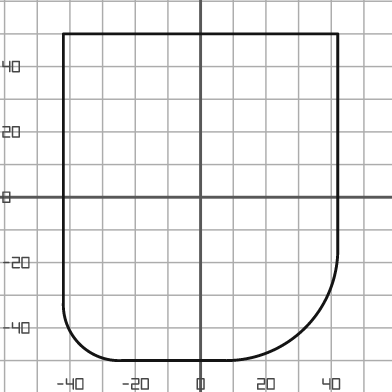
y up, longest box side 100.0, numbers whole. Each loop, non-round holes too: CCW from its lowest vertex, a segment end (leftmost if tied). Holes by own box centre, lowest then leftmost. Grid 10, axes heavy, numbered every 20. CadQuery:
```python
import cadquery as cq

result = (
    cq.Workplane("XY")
    .moveTo(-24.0, -50.0)
    .lineTo(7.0, -50.0)
    .threePointArc((32.0, -40.0), (42.0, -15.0))
    .lineTo(42.0, 50.0)
    .lineTo(-42.0, 50.0)
    .lineTo(-42.0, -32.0)
    .threePointArc((-37.0, -45.0), (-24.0, -50.0))
    .close()
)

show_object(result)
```